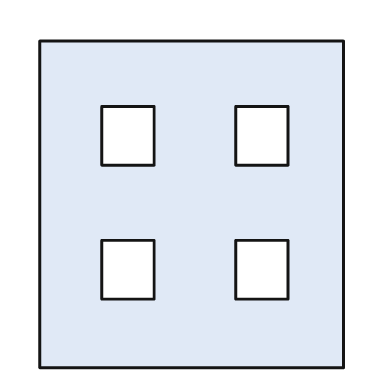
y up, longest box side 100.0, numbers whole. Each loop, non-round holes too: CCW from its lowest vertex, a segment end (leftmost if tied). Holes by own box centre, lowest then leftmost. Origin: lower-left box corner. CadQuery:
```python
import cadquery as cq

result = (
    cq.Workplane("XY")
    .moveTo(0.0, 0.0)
    .lineTo(93.0, 0.0)
    .lineTo(93.0, 100.0)
    .lineTo(0.0, 100.0)
    .close()
    .moveTo(19.0, 21.0)
    .lineTo(35.0, 21.0)
    .lineTo(35.0, 39.0)
    .lineTo(19.0, 39.0)
    .close()
    .moveTo(60.0, 21.0)
    .lineTo(76.0, 21.0)
    .lineTo(76.0, 39.0)
    .lineTo(60.0, 39.0)
    .close()
    .moveTo(19.0, 62.0)
    .lineTo(35.0, 62.0)
    .lineTo(35.0, 80.0)
    .lineTo(19.0, 80.0)
    .close()
    .moveTo(60.0, 62.0)
    .lineTo(76.0, 62.0)
    .lineTo(76.0, 80.0)
    .lineTo(60.0, 80.0)
    .close()
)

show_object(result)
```